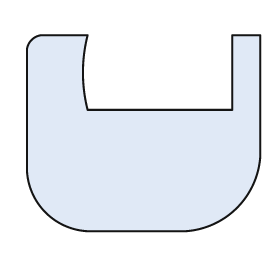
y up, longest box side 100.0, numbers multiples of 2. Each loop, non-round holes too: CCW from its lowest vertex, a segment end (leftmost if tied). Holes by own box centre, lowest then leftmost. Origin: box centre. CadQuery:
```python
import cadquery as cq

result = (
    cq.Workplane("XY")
    .moveTo(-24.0, -42.0)
    .lineTo(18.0, -42.0)
    .threePointArc((40.0, -32.0), (50.0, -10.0))
    .lineTo(50.0, 42.0)
    .lineTo(38.0, 42.0)
    .lineTo(38.0, 10.0)
    .lineTo(-24.0, 10.0)
    .threePointArc((-26.0, 26.0), (-24.0, 42.0))
    .lineTo(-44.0, 42.0)
    .threePointArc((-48.0, 40.0), (-50.0, 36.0))
    .lineTo(-50.0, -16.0)
    .threePointArc((-42.0, -34.0), (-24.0, -42.0))
    .close()
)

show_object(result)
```